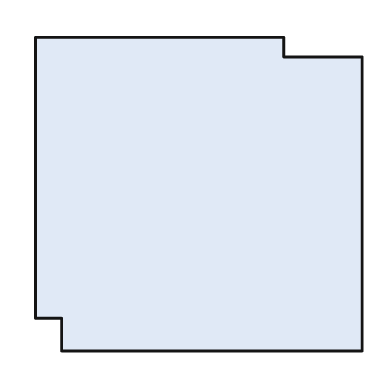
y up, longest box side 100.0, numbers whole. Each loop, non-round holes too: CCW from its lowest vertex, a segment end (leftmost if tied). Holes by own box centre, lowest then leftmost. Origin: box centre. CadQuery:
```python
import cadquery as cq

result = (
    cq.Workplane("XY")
    .moveTo(-42.0, -48.0)
    .lineTo(50.0, -48.0)
    .lineTo(50.0, 42.0)
    .lineTo(26.0, 42.0)
    .lineTo(26.0, 48.0)
    .lineTo(-50.0, 48.0)
    .lineTo(-50.0, -38.0)
    .lineTo(-42.0, -38.0)
    .close()
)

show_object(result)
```